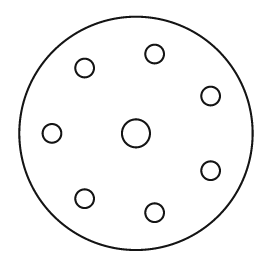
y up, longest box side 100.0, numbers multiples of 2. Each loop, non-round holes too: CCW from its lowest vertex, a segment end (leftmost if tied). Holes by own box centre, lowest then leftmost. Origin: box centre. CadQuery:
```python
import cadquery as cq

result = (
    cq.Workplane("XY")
    .moveTo(0.0, 0.0)
    .circle(50.0)
    .moveTo(8.0, -34.0)
    .circle(4.0)
    .moveTo(-22.0, -28.0)
    .circle(4.0)
    .moveTo(32.0, -16.0)
    .circle(4.0)
    .moveTo(-36.0, 0.0)
    .circle(4.0)
    .moveTo(0.0, 0.0)
    .circle(6.0)
    .moveTo(32.0, 16.0)
    .circle(4.0)
    .moveTo(-22.0, 28.0)
    .circle(4.0)
    .moveTo(8.0, 34.0)
    .circle(4.0)
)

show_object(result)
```